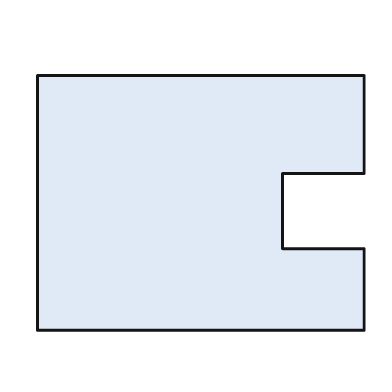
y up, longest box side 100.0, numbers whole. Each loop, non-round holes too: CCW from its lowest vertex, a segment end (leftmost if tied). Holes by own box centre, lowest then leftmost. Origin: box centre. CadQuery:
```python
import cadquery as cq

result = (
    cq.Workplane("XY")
    .moveTo(-50.0, -39.0)
    .lineTo(50.0, -39.0)
    .lineTo(50.0, -14.0)
    .lineTo(25.0, -14.0)
    .lineTo(25.0, 9.0)
    .lineTo(50.0, 9.0)
    .lineTo(50.0, 39.0)
    .lineTo(-50.0, 39.0)
    .close()
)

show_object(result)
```